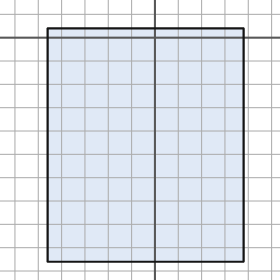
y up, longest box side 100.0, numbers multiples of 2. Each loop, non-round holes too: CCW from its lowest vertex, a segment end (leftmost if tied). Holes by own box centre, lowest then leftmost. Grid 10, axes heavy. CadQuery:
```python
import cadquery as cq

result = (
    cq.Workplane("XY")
    .moveTo(-46.0, -96.0)
    .lineTo(38.0, -96.0)
    .lineTo(38.0, 4.0)
    .lineTo(-46.0, 4.0)
    .close()
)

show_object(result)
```